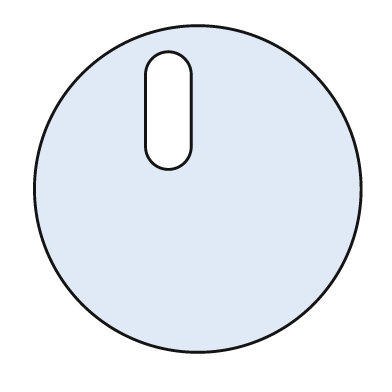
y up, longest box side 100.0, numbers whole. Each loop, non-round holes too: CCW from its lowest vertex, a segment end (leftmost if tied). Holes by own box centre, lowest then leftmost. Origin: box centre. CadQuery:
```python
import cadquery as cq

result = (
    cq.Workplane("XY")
    .moveTo(0.0, 0.0)
    .circle(50.0)
    .moveTo(-16.0, 13.0)
    .threePointArc((-9.0, 6.0), (-2.0, 13.0))
    .lineTo(-2.0, 35.0)
    .threePointArc((-9.0, 42.0), (-16.0, 35.0))
    .close()
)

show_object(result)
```